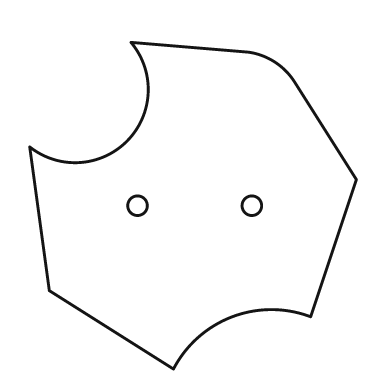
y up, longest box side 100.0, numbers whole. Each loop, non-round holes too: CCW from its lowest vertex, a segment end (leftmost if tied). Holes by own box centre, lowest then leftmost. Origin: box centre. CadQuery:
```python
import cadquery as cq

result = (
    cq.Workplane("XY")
    .moveTo(-6.0, -50.0)
    .threePointArc((12.0, -34.0), (36.0, -34.0))
    .lineTo(50.0, 8.0)
    .lineTo(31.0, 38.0)
    .threePointArc((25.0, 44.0), (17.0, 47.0))
    .lineTo(-19.0, 50.0)
    .threePointArc((-20.0, 20.0), (-50.0, 18.0))
    .lineTo(-44.0, -26.0)
    .close()
    .moveTo(-17.0, 0.0)
    .circle(3.0)
    .moveTo(18.0, 0.0)
    .circle(3.0)
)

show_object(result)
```